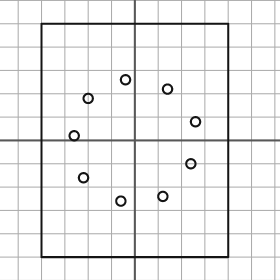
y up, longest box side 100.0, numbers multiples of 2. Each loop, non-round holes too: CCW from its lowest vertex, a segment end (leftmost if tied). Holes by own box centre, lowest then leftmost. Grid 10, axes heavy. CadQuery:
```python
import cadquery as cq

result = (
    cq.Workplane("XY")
    .moveTo(-40.0, -50.0)
    .lineTo(40.0, -50.0)
    .lineTo(40.0, 50.0)
    .lineTo(-40.0, 50.0)
    .close()
    .moveTo(-6.0, -26.0)
    .circle(2.0)
    .moveTo(12.0, -24.0)
    .circle(2.0)
    .moveTo(-22.0, -16.0)
    .circle(2.0)
    .moveTo(24.0, -10.0)
    .circle(2.0)
    .moveTo(-26.0, 2.0)
    .circle(2.0)
    .moveTo(26.0, 8.0)
    .circle(2.0)
    .moveTo(-20.0, 18.0)
    .circle(2.0)
    .moveTo(14.0, 22.0)
    .circle(2.0)
    .moveTo(-4.0, 26.0)
    .circle(2.0)
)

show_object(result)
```